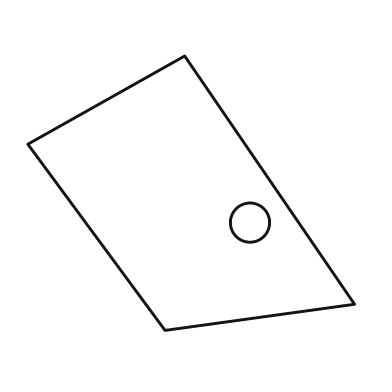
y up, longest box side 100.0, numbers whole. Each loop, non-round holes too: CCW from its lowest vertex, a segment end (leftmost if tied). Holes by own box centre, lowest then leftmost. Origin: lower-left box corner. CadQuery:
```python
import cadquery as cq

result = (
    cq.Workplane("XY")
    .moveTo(42.0, 0.0)
    .lineTo(100.0, 8.0)
    .lineTo(48.0, 84.0)
    .lineTo(0.0, 57.0)
    .close()
    .moveTo(68.0, 33.0)
    .circle(6.0)
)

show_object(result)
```